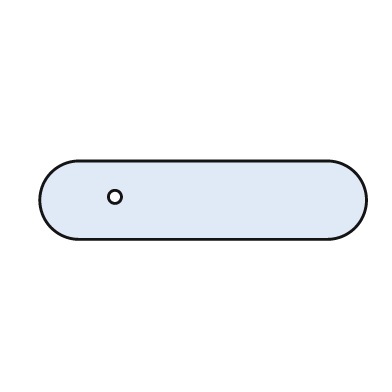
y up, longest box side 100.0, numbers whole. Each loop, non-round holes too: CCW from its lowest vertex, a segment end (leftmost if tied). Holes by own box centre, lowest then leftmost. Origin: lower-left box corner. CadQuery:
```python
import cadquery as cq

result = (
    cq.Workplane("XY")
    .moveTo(12.0, 0.0)
    .lineTo(88.0, 0.0)
    .threePointArc((100.0, 12.0), (88.0, 24.0))
    .lineTo(12.0, 24.0)
    .threePointArc((0.0, 12.0), (12.0, 0.0))
    .close()
    .moveTo(23.0, 13.0)
    .circle(2.0)
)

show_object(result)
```